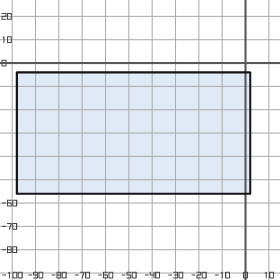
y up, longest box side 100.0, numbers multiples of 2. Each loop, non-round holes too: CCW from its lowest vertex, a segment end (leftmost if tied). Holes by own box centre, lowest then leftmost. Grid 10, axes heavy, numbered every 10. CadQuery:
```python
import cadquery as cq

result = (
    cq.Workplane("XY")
    .moveTo(-98.0, -56.0)
    .lineTo(2.0, -56.0)
    .lineTo(2.0, -4.0)
    .lineTo(-98.0, -4.0)
    .close()
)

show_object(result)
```